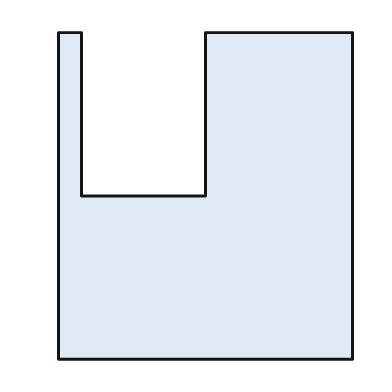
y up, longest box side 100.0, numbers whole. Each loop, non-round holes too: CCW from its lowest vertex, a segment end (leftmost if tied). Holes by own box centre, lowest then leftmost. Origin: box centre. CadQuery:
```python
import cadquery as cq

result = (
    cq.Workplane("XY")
    .moveTo(-45.0, -50.0)
    .lineTo(45.0, -50.0)
    .lineTo(45.0, 50.0)
    .lineTo(0.0, 50.0)
    .lineTo(0.0, 0.0)
    .lineTo(-38.0, 0.0)
    .lineTo(-38.0, 50.0)
    .lineTo(-45.0, 50.0)
    .close()
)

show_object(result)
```